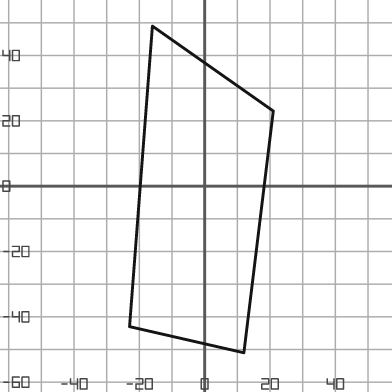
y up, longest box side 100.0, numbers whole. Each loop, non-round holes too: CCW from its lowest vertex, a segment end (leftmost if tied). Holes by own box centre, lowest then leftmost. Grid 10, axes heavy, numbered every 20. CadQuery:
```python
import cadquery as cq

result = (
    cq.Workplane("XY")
    .moveTo(12.0, -51.0)
    .lineTo(21.0, 23.0)
    .lineTo(-16.0, 49.0)
    .lineTo(-23.0, -43.0)
    .close()
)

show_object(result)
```